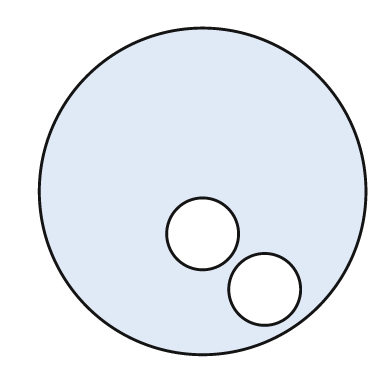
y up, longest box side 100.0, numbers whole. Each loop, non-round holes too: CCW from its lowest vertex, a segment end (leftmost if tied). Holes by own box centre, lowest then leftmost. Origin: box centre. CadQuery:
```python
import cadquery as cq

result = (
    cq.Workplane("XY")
    .moveTo(0.0, 0.0)
    .circle(50.0)
    .moveTo(19.0, -30.0)
    .circle(11.0)
    .moveTo(0.0, -13.0)
    .circle(11.0)
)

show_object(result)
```